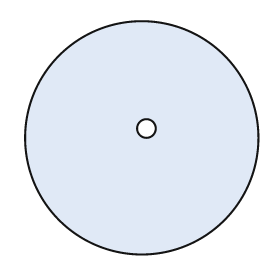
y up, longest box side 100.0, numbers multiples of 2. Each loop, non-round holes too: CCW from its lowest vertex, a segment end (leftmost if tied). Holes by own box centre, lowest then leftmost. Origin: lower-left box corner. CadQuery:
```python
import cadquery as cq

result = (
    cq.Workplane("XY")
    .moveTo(50.0, 50.0)
    .circle(50.0)
    .moveTo(52.0, 54.0)
    .circle(4.0)
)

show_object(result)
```